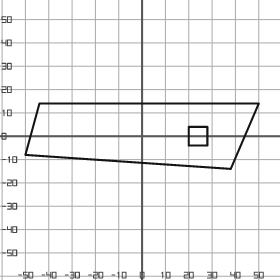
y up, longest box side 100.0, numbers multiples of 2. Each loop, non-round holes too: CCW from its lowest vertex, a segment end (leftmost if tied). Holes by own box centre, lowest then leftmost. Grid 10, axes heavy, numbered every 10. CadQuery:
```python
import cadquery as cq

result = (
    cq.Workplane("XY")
    .moveTo(38.0, -14.0)
    .lineTo(50.0, 14.0)
    .lineTo(-44.0, 14.0)
    .lineTo(-50.0, -8.0)
    .close()
    .moveTo(20.0, -4.0)
    .lineTo(28.0, -4.0)
    .lineTo(28.0, 4.0)
    .lineTo(20.0, 4.0)
    .close()
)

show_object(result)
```